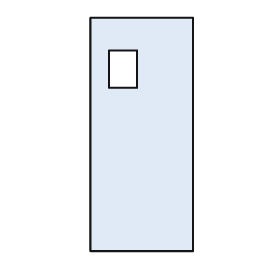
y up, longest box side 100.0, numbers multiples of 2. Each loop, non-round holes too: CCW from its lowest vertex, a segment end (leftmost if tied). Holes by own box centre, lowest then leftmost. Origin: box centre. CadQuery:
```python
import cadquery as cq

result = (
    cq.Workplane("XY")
    .moveTo(-22.0, -50.0)
    .lineTo(22.0, -50.0)
    .lineTo(22.0, 50.0)
    .lineTo(-22.0, 50.0)
    .close()
    .moveTo(-14.0, 20.0)
    .lineTo(-2.0, 20.0)
    .lineTo(-2.0, 36.0)
    .lineTo(-14.0, 36.0)
    .close()
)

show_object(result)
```